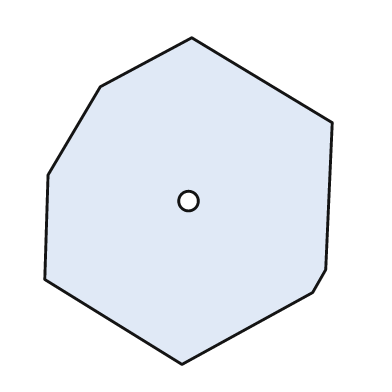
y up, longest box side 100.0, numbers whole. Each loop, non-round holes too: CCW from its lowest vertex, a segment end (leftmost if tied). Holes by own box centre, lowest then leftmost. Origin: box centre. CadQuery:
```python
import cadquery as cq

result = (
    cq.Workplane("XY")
    .moveTo(-2.0, -50.0)
    .lineTo(38.0, -28.0)
    .lineTo(42.0, -21.0)
    .lineTo(44.0, 24.0)
    .lineTo(1.0, 50.0)
    .lineTo(-27.0, 35.0)
    .lineTo(-43.0, 8.0)
    .lineTo(-44.0, -24.0)
    .close()
    .moveTo(0.0, 0.0)
    .circle(3.0)
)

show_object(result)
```